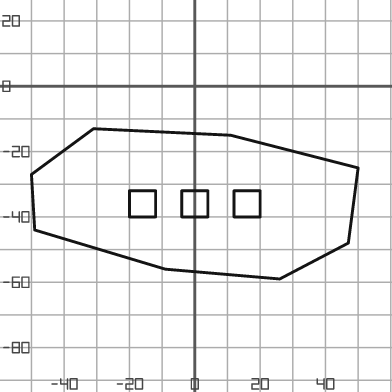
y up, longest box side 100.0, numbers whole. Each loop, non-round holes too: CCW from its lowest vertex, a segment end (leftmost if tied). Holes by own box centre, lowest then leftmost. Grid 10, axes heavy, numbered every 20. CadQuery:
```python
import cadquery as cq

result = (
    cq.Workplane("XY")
    .moveTo(26.0, -59.0)
    .lineTo(47.0, -48.0)
    .lineTo(50.0, -25.0)
    .lineTo(11.0, -15.0)
    .lineTo(-31.0, -13.0)
    .lineTo(-50.0, -27.0)
    .lineTo(-49.0, -44.0)
    .lineTo(-9.0, -56.0)
    .close()
    .moveTo(-20.0, -40.0)
    .lineTo(-12.0, -40.0)
    .lineTo(-12.0, -32.0)
    .lineTo(-20.0, -32.0)
    .close()
    .moveTo(-4.0, -40.0)
    .lineTo(4.0, -40.0)
    .lineTo(4.0, -32.0)
    .lineTo(-4.0, -32.0)
    .close()
    .moveTo(12.0, -40.0)
    .lineTo(20.0, -40.0)
    .lineTo(20.0, -32.0)
    .lineTo(12.0, -32.0)
    .close()
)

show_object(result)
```